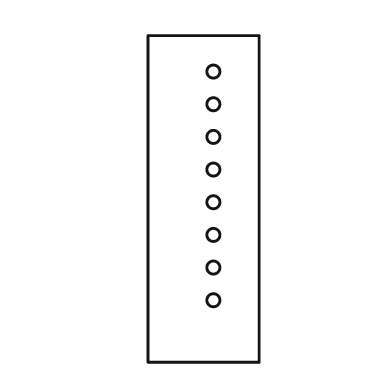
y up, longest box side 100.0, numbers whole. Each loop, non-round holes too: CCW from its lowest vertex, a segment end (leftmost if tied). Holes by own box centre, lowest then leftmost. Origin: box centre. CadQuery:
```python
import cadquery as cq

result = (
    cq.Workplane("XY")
    .moveTo(-17.0, -50.0)
    .lineTo(17.0, -50.0)
    .lineTo(17.0, 50.0)
    .lineTo(-17.0, 50.0)
    .close()
    .moveTo(3.0, -31.0)
    .circle(2.0)
    .moveTo(3.0, -21.0)
    .circle(2.0)
    .moveTo(3.0, -11.0)
    .circle(2.0)
    .moveTo(3.0, -1.0)
    .circle(2.0)
    .moveTo(3.0, 9.0)
    .circle(2.0)
    .moveTo(3.0, 19.0)
    .circle(2.0)
    .moveTo(3.0, 29.0)
    .circle(2.0)
    .moveTo(3.0, 39.0)
    .circle(2.0)
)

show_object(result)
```